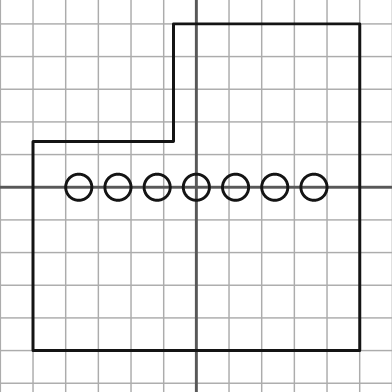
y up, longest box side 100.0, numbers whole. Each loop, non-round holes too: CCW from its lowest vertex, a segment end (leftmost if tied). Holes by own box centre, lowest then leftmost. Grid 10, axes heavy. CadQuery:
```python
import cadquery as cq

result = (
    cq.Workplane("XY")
    .moveTo(-50.0, -50.0)
    .lineTo(50.0, -50.0)
    .lineTo(50.0, 50.0)
    .lineTo(-7.0, 50.0)
    .lineTo(-7.0, 14.0)
    .lineTo(-50.0, 14.0)
    .close()
    .moveTo(-36.0, 0.0)
    .circle(4.0)
    .moveTo(-24.0, 0.0)
    .circle(4.0)
    .moveTo(-12.0, 0.0)
    .circle(4.0)
    .moveTo(0.0, 0.0)
    .circle(4.0)
    .moveTo(12.0, 0.0)
    .circle(4.0)
    .moveTo(24.0, 0.0)
    .circle(4.0)
    .moveTo(36.0, 0.0)
    .circle(4.0)
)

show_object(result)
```